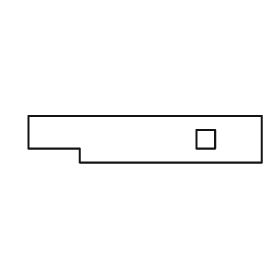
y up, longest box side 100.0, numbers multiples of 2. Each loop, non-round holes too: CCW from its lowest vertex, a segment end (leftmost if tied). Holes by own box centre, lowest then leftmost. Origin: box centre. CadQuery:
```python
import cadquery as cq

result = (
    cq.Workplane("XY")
    .moveTo(-28.0, -10.0)
    .lineTo(50.0, -10.0)
    .lineTo(50.0, 10.0)
    .lineTo(-50.0, 10.0)
    .lineTo(-50.0, -4.0)
    .lineTo(-28.0, -4.0)
    .close()
    .moveTo(22.0, -4.0)
    .lineTo(30.0, -4.0)
    .lineTo(30.0, 4.0)
    .lineTo(22.0, 4.0)
    .close()
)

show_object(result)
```